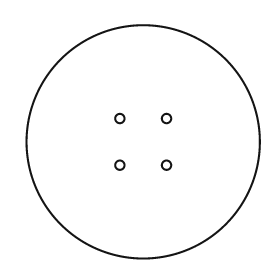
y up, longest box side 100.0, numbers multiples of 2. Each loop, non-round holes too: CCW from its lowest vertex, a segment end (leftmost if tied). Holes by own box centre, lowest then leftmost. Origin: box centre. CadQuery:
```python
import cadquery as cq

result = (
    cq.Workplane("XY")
    .moveTo(0.0, 0.0)
    .circle(50.0)
    .moveTo(-10.0, -10.0)
    .circle(2.0)
    .moveTo(10.0, -10.0)
    .circle(2.0)
    .moveTo(-10.0, 10.0)
    .circle(2.0)
    .moveTo(10.0, 10.0)
    .circle(2.0)
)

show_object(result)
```